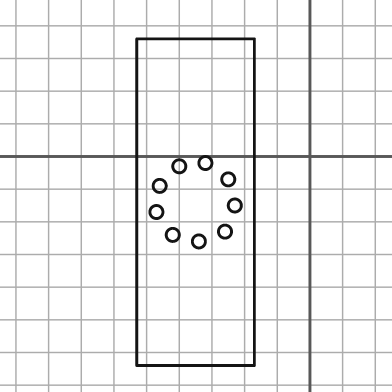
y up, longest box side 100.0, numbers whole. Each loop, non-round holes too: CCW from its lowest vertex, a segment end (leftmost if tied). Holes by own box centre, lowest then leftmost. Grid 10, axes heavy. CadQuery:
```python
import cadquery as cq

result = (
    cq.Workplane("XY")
    .moveTo(-53.0, -64.0)
    .lineTo(-17.0, -64.0)
    .lineTo(-17.0, 36.0)
    .lineTo(-53.0, 36.0)
    .close()
    .moveTo(-34.0, -26.0)
    .circle(2.0)
    .moveTo(-42.0, -24.0)
    .circle(2.0)
    .moveTo(-26.0, -23.0)
    .circle(2.0)
    .moveTo(-47.0, -17.0)
    .circle(2.0)
    .moveTo(-23.0, -15.0)
    .circle(2.0)
    .moveTo(-46.0, -9.0)
    .circle(2.0)
    .moveTo(-25.0, -7.0)
    .circle(2.0)
    .moveTo(-40.0, -3.0)
    .circle(2.0)
    .moveTo(-32.0, -2.0)
    .circle(2.0)
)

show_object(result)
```